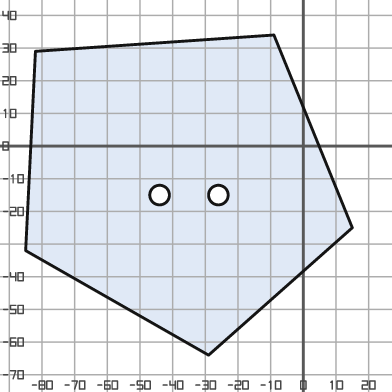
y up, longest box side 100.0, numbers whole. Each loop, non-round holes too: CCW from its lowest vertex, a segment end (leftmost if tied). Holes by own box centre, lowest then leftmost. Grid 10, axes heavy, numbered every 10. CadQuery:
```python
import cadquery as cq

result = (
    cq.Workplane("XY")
    .moveTo(-29.0, -64.0)
    .lineTo(15.0, -25.0)
    .lineTo(-9.0, 34.0)
    .lineTo(-82.0, 29.0)
    .lineTo(-85.0, -32.0)
    .close()
    .moveTo(-44.0, -15.0)
    .circle(3.0)
    .moveTo(-26.0, -15.0)
    .circle(3.0)
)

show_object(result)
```